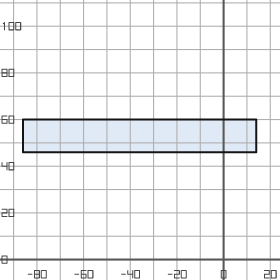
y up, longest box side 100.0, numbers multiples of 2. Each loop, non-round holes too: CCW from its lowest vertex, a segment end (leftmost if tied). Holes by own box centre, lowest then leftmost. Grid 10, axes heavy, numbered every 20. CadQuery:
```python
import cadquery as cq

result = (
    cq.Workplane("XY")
    .moveTo(-86.0, 46.0)
    .lineTo(14.0, 46.0)
    .lineTo(14.0, 60.0)
    .lineTo(-86.0, 60.0)
    .close()
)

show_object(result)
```